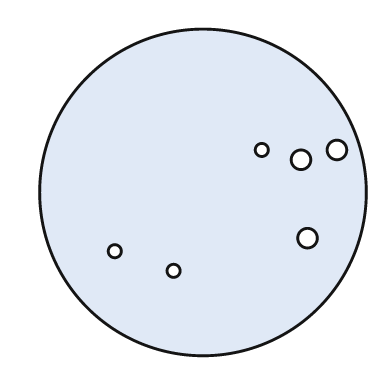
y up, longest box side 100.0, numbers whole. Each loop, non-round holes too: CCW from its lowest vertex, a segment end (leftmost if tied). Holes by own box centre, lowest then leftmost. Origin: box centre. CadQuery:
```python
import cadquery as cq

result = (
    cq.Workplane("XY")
    .moveTo(0.0, 0.0)
    .circle(50.0)
    .moveTo(-9.0, -24.0)
    .circle(2.0)
    .moveTo(-27.0, -18.0)
    .circle(2.0)
    .moveTo(32.0, -14.0)
    .circle(3.0)
    .moveTo(30.0, 10.0)
    .circle(3.0)
    .moveTo(18.0, 13.0)
    .circle(2.0)
    .moveTo(41.0, 13.0)
    .circle(3.0)
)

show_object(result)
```